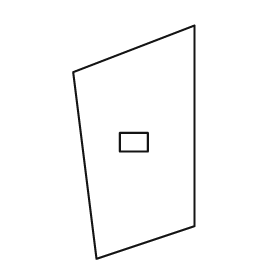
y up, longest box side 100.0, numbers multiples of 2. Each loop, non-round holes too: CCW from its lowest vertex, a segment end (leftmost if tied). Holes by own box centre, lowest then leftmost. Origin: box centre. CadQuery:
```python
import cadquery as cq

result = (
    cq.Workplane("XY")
    .moveTo(-16.0, -50.0)
    .lineTo(26.0, -36.0)
    .lineTo(26.0, 50.0)
    .lineTo(-26.0, 30.0)
    .close()
    .moveTo(-6.0, -4.0)
    .lineTo(6.0, -4.0)
    .lineTo(6.0, 4.0)
    .lineTo(-6.0, 4.0)
    .close()
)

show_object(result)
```